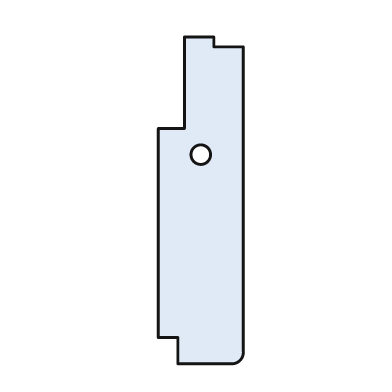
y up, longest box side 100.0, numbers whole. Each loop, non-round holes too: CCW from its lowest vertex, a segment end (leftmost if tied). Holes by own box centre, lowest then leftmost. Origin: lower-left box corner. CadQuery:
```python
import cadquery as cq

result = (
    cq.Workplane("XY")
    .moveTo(6.0, 0.0)
    .lineTo(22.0, 0.0)
    .threePointArc((25.0, 1.0), (26.0, 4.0))
    .lineTo(26.0, 97.0)
    .lineTo(17.0, 97.0)
    .lineTo(17.0, 100.0)
    .lineTo(8.0, 100.0)
    .lineTo(8.0, 72.0)
    .lineTo(0.0, 72.0)
    .lineTo(0.0, 8.0)
    .lineTo(6.0, 8.0)
    .close()
    .moveTo(13.0, 64.0)
    .circle(3.0)
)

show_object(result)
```